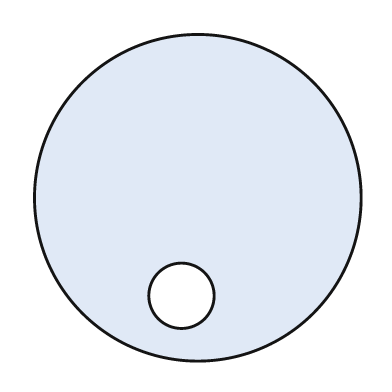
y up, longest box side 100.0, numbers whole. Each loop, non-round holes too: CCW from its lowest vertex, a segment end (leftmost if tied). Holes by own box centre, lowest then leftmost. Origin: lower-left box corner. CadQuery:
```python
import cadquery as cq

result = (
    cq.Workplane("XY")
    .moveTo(50.0, 50.0)
    .circle(50.0)
    .moveTo(45.0, 20.0)
    .circle(10.0)
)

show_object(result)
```